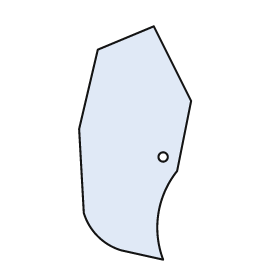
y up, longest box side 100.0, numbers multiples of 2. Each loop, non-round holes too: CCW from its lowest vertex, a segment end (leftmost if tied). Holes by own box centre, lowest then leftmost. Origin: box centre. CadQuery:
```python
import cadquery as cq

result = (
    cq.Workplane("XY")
    .moveTo(12.0, -50.0)
    .threePointArc((10.0, -30.0), (18.0, -12.0))
    .lineTo(24.0, 18.0)
    .lineTo(8.0, 50.0)
    .lineTo(-16.0, 40.0)
    .lineTo(-24.0, 6.0)
    .lineTo(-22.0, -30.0)
    .threePointArc((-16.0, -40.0), (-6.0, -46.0))
    .close()
    .moveTo(12.0, -6.0)
    .circle(2.0)
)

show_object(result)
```